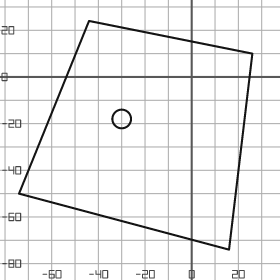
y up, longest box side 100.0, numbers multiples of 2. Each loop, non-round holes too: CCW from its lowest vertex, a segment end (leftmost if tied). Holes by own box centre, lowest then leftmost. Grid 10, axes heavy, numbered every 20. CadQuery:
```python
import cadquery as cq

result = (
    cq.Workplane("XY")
    .moveTo(16.0, -74.0)
    .lineTo(26.0, 10.0)
    .lineTo(-44.0, 24.0)
    .lineTo(-74.0, -50.0)
    .close()
    .moveTo(-30.0, -18.0)
    .circle(4.0)
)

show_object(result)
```